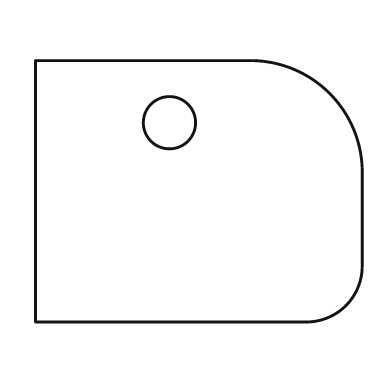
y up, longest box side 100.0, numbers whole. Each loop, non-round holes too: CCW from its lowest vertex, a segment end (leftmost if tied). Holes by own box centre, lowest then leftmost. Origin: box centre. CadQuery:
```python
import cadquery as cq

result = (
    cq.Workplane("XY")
    .moveTo(-50.0, -40.0)
    .lineTo(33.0, -40.0)
    .threePointArc((45.0, -35.0), (50.0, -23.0))
    .lineTo(50.0, 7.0)
    .threePointArc((40.0, 30.0), (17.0, 40.0))
    .lineTo(-50.0, 40.0)
    .close()
    .moveTo(-9.0, 21.0)
    .circle(8.0)
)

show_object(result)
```